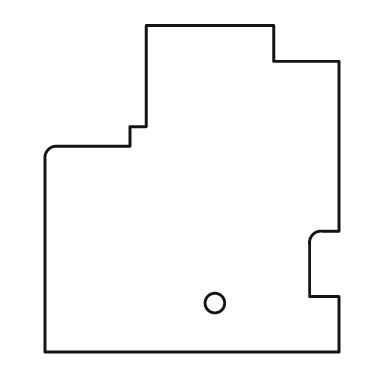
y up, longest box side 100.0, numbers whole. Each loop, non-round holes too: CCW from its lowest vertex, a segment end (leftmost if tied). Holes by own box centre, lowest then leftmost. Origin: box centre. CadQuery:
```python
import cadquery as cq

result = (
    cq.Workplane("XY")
    .moveTo(-45.0, -50.0)
    .lineTo(45.0, -50.0)
    .lineTo(45.0, -33.0)
    .lineTo(36.0, -33.0)
    .lineTo(36.0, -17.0)
    .threePointArc((37.0, -14.0), (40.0, -13.0))
    .lineTo(45.0, -13.0)
    .lineTo(45.0, 39.0)
    .lineTo(25.0, 39.0)
    .lineTo(25.0, 50.0)
    .lineTo(-14.0, 50.0)
    .lineTo(-14.0, 19.0)
    .lineTo(-19.0, 19.0)
    .lineTo(-19.0, 13.0)
    .lineTo(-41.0, 13.0)
    .threePointArc((-44.0, 12.0), (-45.0, 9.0))
    .close()
    .moveTo(7.0, -35.0)
    .circle(3.0)
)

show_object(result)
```